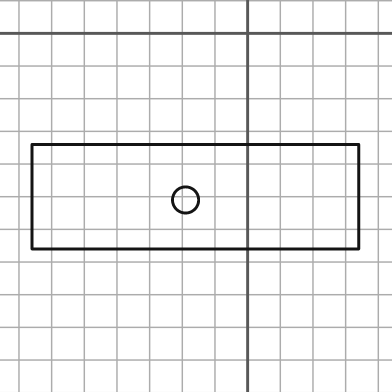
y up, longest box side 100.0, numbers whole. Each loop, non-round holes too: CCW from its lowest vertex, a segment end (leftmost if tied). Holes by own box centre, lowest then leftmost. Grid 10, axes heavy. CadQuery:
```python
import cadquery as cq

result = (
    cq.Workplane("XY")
    .moveTo(-66.0, -66.0)
    .lineTo(34.0, -66.0)
    .lineTo(34.0, -34.0)
    .lineTo(-66.0, -34.0)
    .close()
    .moveTo(-19.0, -51.0)
    .circle(4.0)
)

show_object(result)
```